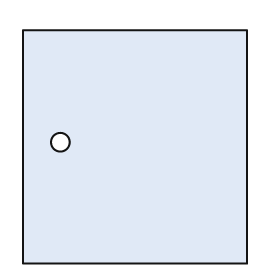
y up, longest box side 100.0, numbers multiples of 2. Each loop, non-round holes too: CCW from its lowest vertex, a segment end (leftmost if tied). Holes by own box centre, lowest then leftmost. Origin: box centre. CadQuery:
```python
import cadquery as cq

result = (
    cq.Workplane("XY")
    .moveTo(-48.0, -50.0)
    .lineTo(48.0, -50.0)
    .lineTo(48.0, 50.0)
    .lineTo(-48.0, 50.0)
    .close()
    .moveTo(-32.0, 2.0)
    .circle(4.0)
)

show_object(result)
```